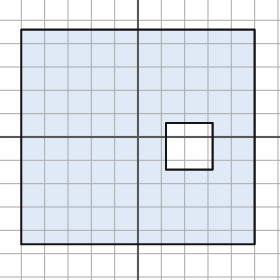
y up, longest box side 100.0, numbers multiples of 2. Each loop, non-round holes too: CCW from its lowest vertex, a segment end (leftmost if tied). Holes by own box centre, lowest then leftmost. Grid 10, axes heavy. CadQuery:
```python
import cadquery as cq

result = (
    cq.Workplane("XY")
    .moveTo(-50.0, -46.0)
    .lineTo(50.0, -46.0)
    .lineTo(50.0, 46.0)
    .lineTo(-50.0, 46.0)
    .close()
    .moveTo(12.0, -14.0)
    .lineTo(32.0, -14.0)
    .lineTo(32.0, 6.0)
    .lineTo(12.0, 6.0)
    .close()
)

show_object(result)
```